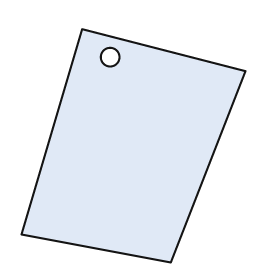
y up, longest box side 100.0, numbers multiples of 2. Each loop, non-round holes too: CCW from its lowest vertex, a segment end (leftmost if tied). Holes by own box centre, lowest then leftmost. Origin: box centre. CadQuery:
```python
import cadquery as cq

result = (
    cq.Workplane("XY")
    .moveTo(16.0, -50.0)
    .lineTo(48.0, 32.0)
    .lineTo(-22.0, 50.0)
    .lineTo(-48.0, -38.0)
    .close()
    .moveTo(-10.0, 38.0)
    .circle(4.0)
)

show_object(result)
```